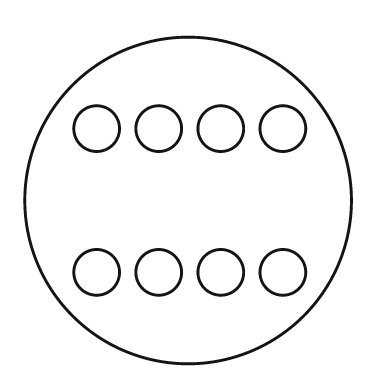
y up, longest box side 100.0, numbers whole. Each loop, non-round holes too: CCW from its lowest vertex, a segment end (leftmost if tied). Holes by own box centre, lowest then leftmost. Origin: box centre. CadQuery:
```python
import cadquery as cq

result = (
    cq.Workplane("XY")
    .moveTo(0.0, 0.0)
    .circle(50.0)
    .moveTo(-28.0, -22.0)
    .circle(7.0)
    .moveTo(-9.0, -22.0)
    .circle(7.0)
    .moveTo(10.0, -22.0)
    .circle(7.0)
    .moveTo(29.0, -22.0)
    .circle(7.0)
    .moveTo(-28.0, 22.0)
    .circle(7.0)
    .moveTo(-9.0, 22.0)
    .circle(7.0)
    .moveTo(10.0, 22.0)
    .circle(7.0)
    .moveTo(29.0, 22.0)
    .circle(7.0)
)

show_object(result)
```